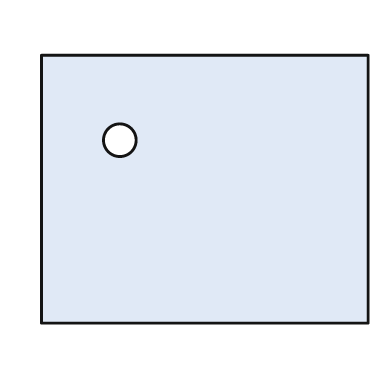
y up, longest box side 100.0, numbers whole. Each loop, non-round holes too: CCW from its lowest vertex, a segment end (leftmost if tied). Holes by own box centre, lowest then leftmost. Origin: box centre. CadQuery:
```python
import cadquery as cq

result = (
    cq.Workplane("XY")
    .moveTo(-50.0, -41.0)
    .lineTo(50.0, -41.0)
    .lineTo(50.0, 41.0)
    .lineTo(-50.0, 41.0)
    .close()
    .moveTo(-26.0, 15.0)
    .circle(5.0)
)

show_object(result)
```